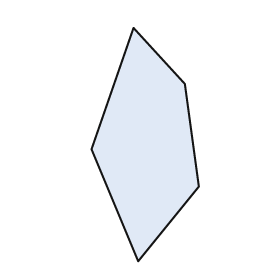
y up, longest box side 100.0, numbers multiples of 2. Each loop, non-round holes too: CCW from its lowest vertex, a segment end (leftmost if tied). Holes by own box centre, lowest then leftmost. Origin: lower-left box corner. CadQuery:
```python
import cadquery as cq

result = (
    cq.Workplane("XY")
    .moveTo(20.0, 0.0)
    .lineTo(46.0, 32.0)
    .lineTo(40.0, 76.0)
    .lineTo(18.0, 100.0)
    .lineTo(0.0, 48.0)
    .close()
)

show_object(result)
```